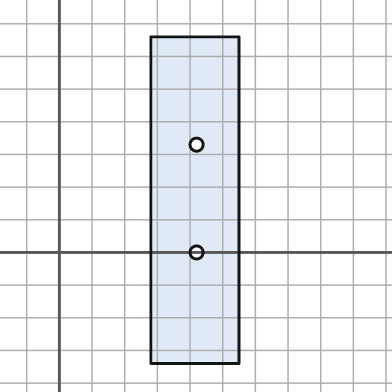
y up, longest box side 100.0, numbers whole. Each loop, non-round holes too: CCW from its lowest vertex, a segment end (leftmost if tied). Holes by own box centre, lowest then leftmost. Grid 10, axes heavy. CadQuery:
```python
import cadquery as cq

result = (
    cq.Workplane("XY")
    .moveTo(28.0, -34.0)
    .lineTo(55.0, -34.0)
    .lineTo(55.0, 66.0)
    .lineTo(28.0, 66.0)
    .close()
    .moveTo(42.0, 0.0)
    .circle(2.0)
    .moveTo(42.0, 33.0)
    .circle(2.0)
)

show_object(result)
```